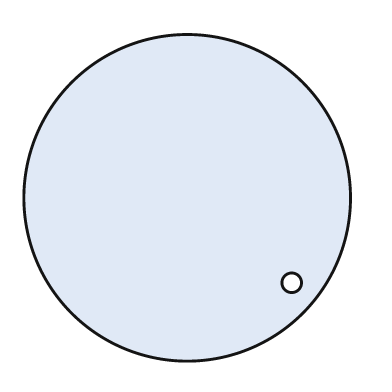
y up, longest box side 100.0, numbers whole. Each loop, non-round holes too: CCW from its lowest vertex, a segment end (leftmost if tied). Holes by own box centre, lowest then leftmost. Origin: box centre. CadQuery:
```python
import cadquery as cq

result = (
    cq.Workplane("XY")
    .moveTo(0.0, 0.0)
    .circle(50.0)
    .moveTo(32.0, -26.0)
    .circle(3.0)
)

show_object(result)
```